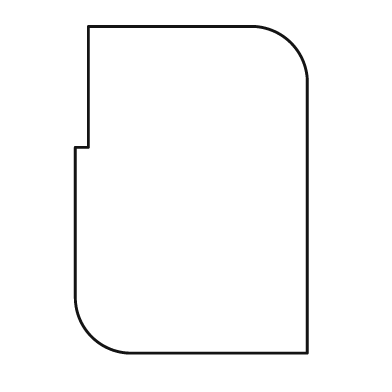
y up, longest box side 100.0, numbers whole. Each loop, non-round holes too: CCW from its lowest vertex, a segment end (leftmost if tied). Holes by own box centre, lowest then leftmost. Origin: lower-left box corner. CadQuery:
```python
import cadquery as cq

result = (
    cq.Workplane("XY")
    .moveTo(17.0, 0.0)
    .lineTo(71.0, 0.0)
    .lineTo(71.0, 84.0)
    .threePointArc((66.0, 95.0), (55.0, 100.0))
    .lineTo(4.0, 100.0)
    .lineTo(4.0, 63.0)
    .lineTo(0.0, 63.0)
    .lineTo(0.0, 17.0)
    .threePointArc((5.0, 5.0), (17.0, 0.0))
    .close()
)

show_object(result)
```